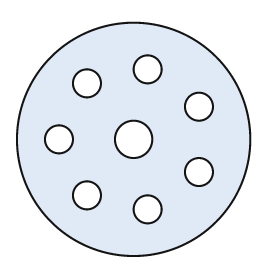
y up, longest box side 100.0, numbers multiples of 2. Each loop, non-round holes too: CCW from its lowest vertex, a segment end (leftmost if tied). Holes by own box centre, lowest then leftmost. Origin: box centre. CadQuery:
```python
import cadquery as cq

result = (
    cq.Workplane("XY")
    .moveTo(0.0, 0.0)
    .circle(50.0)
    .moveTo(6.0, -30.0)
    .circle(6.0)
    .moveTo(-20.0, -24.0)
    .circle(6.0)
    .moveTo(28.0, -14.0)
    .circle(6.0)
    .moveTo(-32.0, 0.0)
    .circle(6.0)
    .moveTo(0.0, 0.0)
    .circle(8.0)
    .moveTo(28.0, 14.0)
    .circle(6.0)
    .moveTo(-20.0, 24.0)
    .circle(6.0)
    .moveTo(6.0, 30.0)
    .circle(6.0)
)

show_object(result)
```